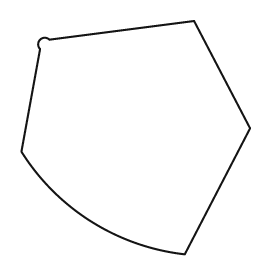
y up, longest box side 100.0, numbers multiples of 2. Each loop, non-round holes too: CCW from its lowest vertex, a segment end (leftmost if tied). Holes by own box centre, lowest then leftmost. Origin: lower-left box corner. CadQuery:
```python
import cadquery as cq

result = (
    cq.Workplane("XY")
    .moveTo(70.0, 0.0)
    .lineTo(98.0, 54.0)
    .lineTo(74.0, 100.0)
    .lineTo(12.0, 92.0)
    .threePointArc((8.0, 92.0), (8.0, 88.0))
    .lineTo(0.0, 44.0)
    .threePointArc((30.0, 14.0), (70.0, 0.0))
    .close()
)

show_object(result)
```